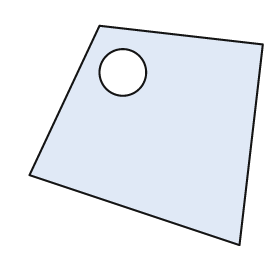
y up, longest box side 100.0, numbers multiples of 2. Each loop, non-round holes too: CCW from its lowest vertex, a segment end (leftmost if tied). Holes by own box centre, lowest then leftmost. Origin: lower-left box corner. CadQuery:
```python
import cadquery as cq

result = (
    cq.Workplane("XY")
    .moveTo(90.0, 0.0)
    .lineTo(100.0, 86.0)
    .lineTo(30.0, 94.0)
    .lineTo(0.0, 30.0)
    .close()
    .moveTo(40.0, 74.0)
    .circle(10.0)
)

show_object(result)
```